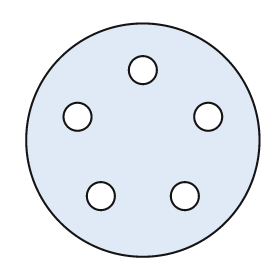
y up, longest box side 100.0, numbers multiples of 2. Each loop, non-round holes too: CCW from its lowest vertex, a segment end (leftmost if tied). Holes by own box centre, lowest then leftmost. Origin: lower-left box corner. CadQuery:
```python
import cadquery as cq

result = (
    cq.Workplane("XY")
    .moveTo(50.0, 50.0)
    .circle(50.0)
    .moveTo(32.0, 26.0)
    .circle(6.0)
    .moveTo(68.0, 26.0)
    .circle(6.0)
    .moveTo(22.0, 60.0)
    .circle(6.0)
    .moveTo(78.0, 60.0)
    .circle(6.0)
    .moveTo(50.0, 80.0)
    .circle(6.0)
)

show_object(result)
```